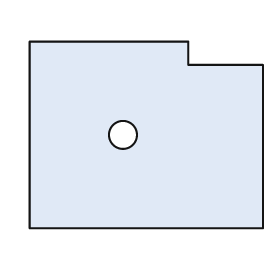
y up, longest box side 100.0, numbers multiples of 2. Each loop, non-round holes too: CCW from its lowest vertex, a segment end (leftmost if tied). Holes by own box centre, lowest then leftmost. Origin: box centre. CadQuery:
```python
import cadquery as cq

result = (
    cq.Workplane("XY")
    .moveTo(-50.0, -40.0)
    .lineTo(50.0, -40.0)
    .lineTo(50.0, 30.0)
    .lineTo(18.0, 30.0)
    .lineTo(18.0, 40.0)
    .lineTo(-50.0, 40.0)
    .close()
    .moveTo(-10.0, 0.0)
    .circle(6.0)
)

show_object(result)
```